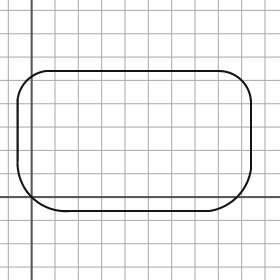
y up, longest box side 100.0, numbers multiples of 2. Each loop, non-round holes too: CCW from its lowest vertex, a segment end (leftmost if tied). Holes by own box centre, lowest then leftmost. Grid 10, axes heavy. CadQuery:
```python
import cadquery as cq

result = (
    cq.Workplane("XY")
    .moveTo(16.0, -6.0)
    .lineTo(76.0, -6.0)
    .threePointArc((88.0, 0.0), (94.0, 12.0))
    .lineTo(94.0, 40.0)
    .threePointArc((90.0, 50.0), (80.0, 54.0))
    .lineTo(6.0, 54.0)
    .threePointArc((-2.0, 50.0), (-6.0, 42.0))
    .lineTo(-6.0, 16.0)
    .threePointArc((0.0, 0.0), (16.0, -6.0))
    .close()
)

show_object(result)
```